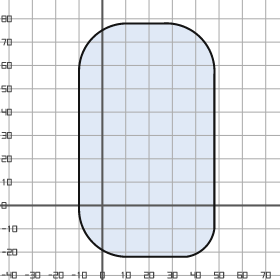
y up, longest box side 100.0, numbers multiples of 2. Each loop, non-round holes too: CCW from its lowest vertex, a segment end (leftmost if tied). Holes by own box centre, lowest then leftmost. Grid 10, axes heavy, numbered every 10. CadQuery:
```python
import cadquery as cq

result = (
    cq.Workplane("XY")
    .moveTo(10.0, -22.0)
    .lineTo(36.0, -22.0)
    .threePointArc((44.0, -18.0), (48.0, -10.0))
    .lineTo(48.0, 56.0)
    .threePointArc((42.0, 72.0), (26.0, 78.0))
    .lineTo(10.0, 78.0)
    .threePointArc((-4.0, 72.0), (-10.0, 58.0))
    .lineTo(-10.0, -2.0)
    .threePointArc((-4.0, -16.0), (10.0, -22.0))
    .close()
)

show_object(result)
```